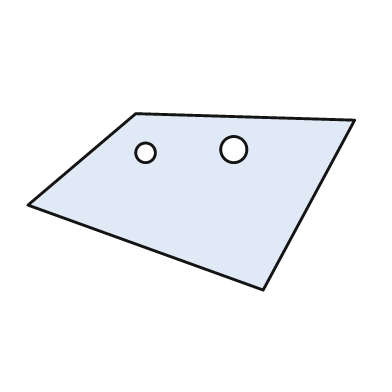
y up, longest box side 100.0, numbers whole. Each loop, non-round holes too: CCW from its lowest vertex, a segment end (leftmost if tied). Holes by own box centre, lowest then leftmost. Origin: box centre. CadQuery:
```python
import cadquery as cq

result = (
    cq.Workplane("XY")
    .moveTo(22.0, -27.0)
    .lineTo(50.0, 25.0)
    .lineTo(-17.0, 27.0)
    .lineTo(-50.0, -1.0)
    .close()
    .moveTo(-14.0, 15.0)
    .circle(3.0)
    .moveTo(13.0, 16.0)
    .circle(4.0)
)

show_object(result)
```